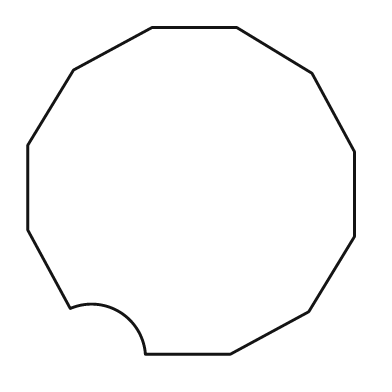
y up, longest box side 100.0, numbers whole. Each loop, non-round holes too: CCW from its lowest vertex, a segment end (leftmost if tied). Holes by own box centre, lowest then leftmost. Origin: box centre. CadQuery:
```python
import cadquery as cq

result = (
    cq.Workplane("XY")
    .moveTo(-14.0, -50.0)
    .lineTo(12.0, -50.0)
    .lineTo(36.0, -37.0)
    .lineTo(50.0, -14.0)
    .lineTo(50.0, 12.0)
    .lineTo(37.0, 36.0)
    .lineTo(14.0, 50.0)
    .lineTo(-12.0, 50.0)
    .lineTo(-36.0, 37.0)
    .lineTo(-50.0, 14.0)
    .lineTo(-50.0, -12.0)
    .lineTo(-37.0, -36.0)
    .threePointArc((-22.0, -37.0), (-14.0, -50.0))
    .close()
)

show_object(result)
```